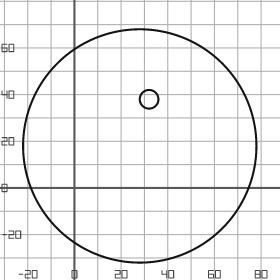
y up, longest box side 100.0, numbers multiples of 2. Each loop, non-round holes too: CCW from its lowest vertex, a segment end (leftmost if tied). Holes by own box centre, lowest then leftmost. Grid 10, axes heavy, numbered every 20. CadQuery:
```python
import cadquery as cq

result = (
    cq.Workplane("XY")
    .moveTo(28.0, 18.0)
    .circle(50.0)
    .moveTo(32.0, 38.0)
    .circle(4.0)
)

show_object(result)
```